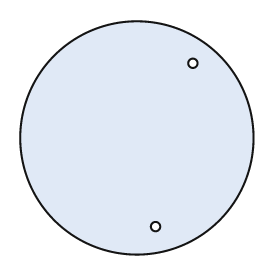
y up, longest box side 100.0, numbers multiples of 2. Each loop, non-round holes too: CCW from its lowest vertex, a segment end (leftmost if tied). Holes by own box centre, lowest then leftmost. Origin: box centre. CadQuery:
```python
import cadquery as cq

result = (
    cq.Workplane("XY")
    .moveTo(0.0, 0.0)
    .circle(50.0)
    .moveTo(8.0, -38.0)
    .circle(2.0)
    .moveTo(24.0, 32.0)
    .circle(2.0)
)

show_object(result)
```